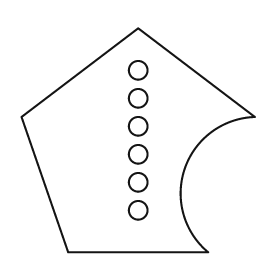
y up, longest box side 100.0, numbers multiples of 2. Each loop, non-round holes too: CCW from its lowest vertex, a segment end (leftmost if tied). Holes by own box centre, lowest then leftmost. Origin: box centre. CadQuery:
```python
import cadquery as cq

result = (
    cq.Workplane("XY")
    .moveTo(-30.0, -48.0)
    .lineTo(30.0, -48.0)
    .threePointArc((20.0, -12.0), (50.0, 10.0))
    .lineTo(0.0, 48.0)
    .lineTo(-50.0, 10.0)
    .close()
    .moveTo(0.0, -30.0)
    .circle(4.0)
    .moveTo(0.0, -18.0)
    .circle(4.0)
    .moveTo(0.0, -6.0)
    .circle(4.0)
    .moveTo(0.0, 6.0)
    .circle(4.0)
    .moveTo(0.0, 18.0)
    .circle(4.0)
    .moveTo(0.0, 30.0)
    .circle(4.0)
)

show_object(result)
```